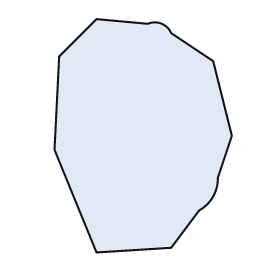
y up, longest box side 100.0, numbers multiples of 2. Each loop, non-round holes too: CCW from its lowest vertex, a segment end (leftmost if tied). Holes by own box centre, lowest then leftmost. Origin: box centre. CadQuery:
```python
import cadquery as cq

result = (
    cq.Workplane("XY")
    .moveTo(-20.0, -50.0)
    .lineTo(12.0, -48.0)
    .lineTo(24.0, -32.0)
    .threePointArc((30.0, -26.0), (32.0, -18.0))
    .lineTo(38.0, 0.0)
    .lineTo(30.0, 32.0)
    .lineTo(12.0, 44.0)
    .threePointArc((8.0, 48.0), (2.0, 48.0))
    .lineTo(-20.0, 50.0)
    .lineTo(-36.0, 34.0)
    .lineTo(-38.0, -6.0)
    .close()
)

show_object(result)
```